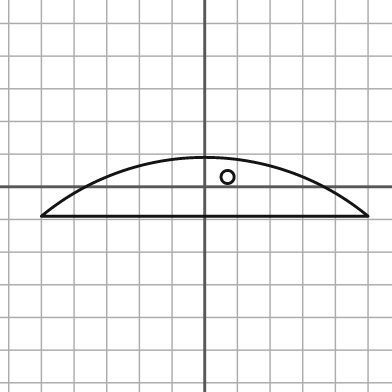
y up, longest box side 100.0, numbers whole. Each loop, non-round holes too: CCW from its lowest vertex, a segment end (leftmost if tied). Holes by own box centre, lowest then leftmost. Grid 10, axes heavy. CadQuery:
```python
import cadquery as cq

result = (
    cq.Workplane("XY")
    .moveTo(-50.0, -9.0)
    .lineTo(50.0, -9.0)
    .threePointArc((0.0, 9.0), (-50.0, -9.0))
    .close()
    .moveTo(7.0, 3.0)
    .circle(2.0)
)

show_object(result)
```